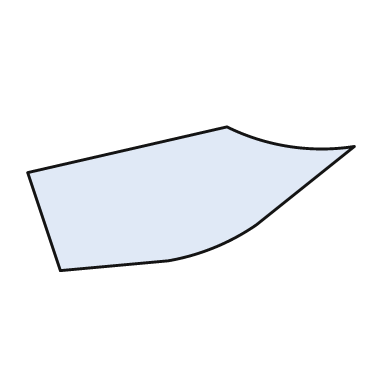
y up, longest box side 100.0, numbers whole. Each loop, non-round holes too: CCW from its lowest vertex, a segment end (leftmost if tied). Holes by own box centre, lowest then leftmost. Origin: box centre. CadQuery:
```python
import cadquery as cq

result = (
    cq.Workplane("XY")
    .moveTo(-40.0, -22.0)
    .lineTo(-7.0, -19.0)
    .threePointArc((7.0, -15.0), (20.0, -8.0))
    .lineTo(50.0, 16.0)
    .threePointArc((30.0, 16.0), (11.0, 22.0))
    .lineTo(-50.0, 8.0)
    .close()
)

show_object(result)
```